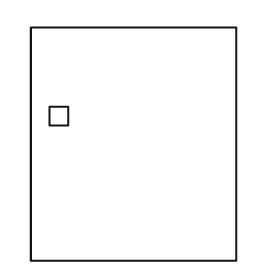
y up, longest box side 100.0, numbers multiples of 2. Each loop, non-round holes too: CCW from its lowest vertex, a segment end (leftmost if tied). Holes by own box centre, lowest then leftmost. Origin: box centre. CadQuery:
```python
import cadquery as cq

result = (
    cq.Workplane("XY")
    .moveTo(-44.0, -50.0)
    .lineTo(44.0, -50.0)
    .lineTo(44.0, 50.0)
    .lineTo(-44.0, 50.0)
    .close()
    .moveTo(-36.0, 8.0)
    .lineTo(-28.0, 8.0)
    .lineTo(-28.0, 16.0)
    .lineTo(-36.0, 16.0)
    .close()
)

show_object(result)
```